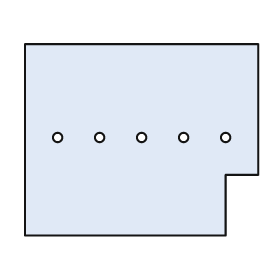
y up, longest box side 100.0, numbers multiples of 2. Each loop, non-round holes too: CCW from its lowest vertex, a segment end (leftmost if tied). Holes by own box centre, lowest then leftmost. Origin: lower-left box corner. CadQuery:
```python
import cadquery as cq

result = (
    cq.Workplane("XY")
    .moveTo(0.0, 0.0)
    .lineTo(86.0, 0.0)
    .lineTo(86.0, 26.0)
    .lineTo(100.0, 26.0)
    .lineTo(100.0, 82.0)
    .lineTo(0.0, 82.0)
    .close()
    .moveTo(14.0, 42.0)
    .circle(2.0)
    .moveTo(32.0, 42.0)
    .circle(2.0)
    .moveTo(50.0, 42.0)
    .circle(2.0)
    .moveTo(68.0, 42.0)
    .circle(2.0)
    .moveTo(86.0, 42.0)
    .circle(2.0)
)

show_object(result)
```